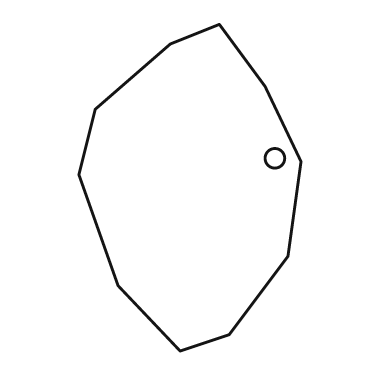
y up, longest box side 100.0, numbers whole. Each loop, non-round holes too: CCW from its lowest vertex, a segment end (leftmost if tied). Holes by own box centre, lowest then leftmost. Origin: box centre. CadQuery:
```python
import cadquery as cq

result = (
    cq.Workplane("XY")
    .moveTo(-3.0, -50.0)
    .lineTo(12.0, -45.0)
    .lineTo(30.0, -21.0)
    .lineTo(34.0, 8.0)
    .lineTo(23.0, 31.0)
    .lineTo(9.0, 50.0)
    .lineTo(-6.0, 44.0)
    .lineTo(-29.0, 24.0)
    .lineTo(-34.0, 4.0)
    .lineTo(-22.0, -30.0)
    .close()
    .moveTo(26.0, 9.0)
    .circle(3.0)
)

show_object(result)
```